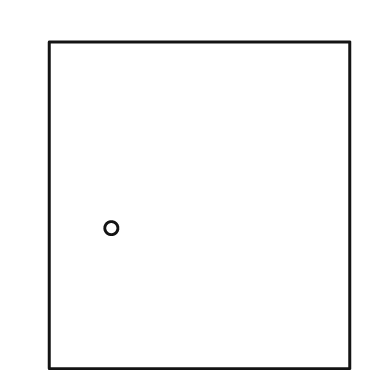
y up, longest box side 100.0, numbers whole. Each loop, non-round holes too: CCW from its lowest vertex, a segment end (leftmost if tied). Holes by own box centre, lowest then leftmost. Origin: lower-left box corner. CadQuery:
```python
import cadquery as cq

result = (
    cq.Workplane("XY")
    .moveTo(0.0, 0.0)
    .lineTo(92.0, 0.0)
    .lineTo(92.0, 100.0)
    .lineTo(0.0, 100.0)
    .close()
    .moveTo(19.0, 43.0)
    .circle(2.0)
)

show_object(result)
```